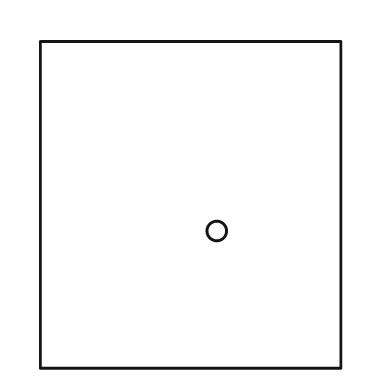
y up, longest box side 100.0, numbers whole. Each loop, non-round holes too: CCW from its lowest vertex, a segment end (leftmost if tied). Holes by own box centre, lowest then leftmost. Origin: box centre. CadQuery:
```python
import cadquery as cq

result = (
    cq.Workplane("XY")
    .moveTo(-46.0, -50.0)
    .lineTo(46.0, -50.0)
    .lineTo(46.0, 50.0)
    .lineTo(-46.0, 50.0)
    .close()
    .moveTo(8.0, -8.0)
    .circle(3.0)
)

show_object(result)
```